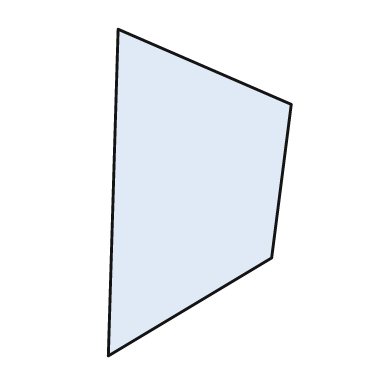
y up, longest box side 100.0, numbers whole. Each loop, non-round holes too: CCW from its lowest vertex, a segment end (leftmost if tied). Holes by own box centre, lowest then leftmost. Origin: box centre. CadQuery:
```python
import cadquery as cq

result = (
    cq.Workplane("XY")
    .moveTo(-28.0, -50.0)
    .lineTo(22.0, -20.0)
    .lineTo(28.0, 27.0)
    .lineTo(-25.0, 50.0)
    .close()
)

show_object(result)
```